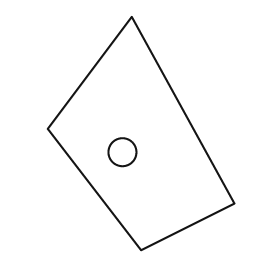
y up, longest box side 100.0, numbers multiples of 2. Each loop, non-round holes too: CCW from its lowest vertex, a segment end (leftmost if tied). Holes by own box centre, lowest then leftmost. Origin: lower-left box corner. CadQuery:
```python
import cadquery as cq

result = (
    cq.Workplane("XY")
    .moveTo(40.0, 0.0)
    .lineTo(80.0, 20.0)
    .lineTo(36.0, 100.0)
    .lineTo(0.0, 52.0)
    .close()
    .moveTo(32.0, 42.0)
    .circle(6.0)
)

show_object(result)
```